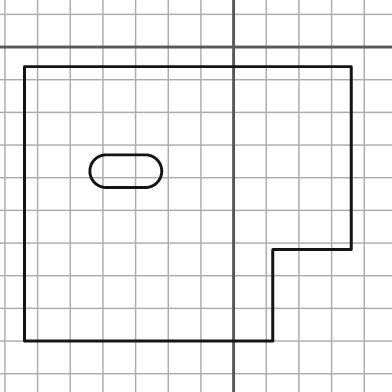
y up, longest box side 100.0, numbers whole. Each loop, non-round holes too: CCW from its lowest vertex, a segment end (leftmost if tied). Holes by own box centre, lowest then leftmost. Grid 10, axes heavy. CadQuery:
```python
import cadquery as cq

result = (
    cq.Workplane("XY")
    .moveTo(-64.0, -90.0)
    .lineTo(12.0, -90.0)
    .lineTo(12.0, -62.0)
    .lineTo(36.0, -62.0)
    .lineTo(36.0, -6.0)
    .lineTo(-64.0, -6.0)
    .close()
    .moveTo(-39.0, -43.0)
    .lineTo(-27.0, -43.0)
    .threePointArc((-22.0, -38.0), (-27.0, -33.0))
    .lineTo(-39.0, -33.0)
    .threePointArc((-44.0, -38.0), (-39.0, -43.0))
    .close()
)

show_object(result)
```